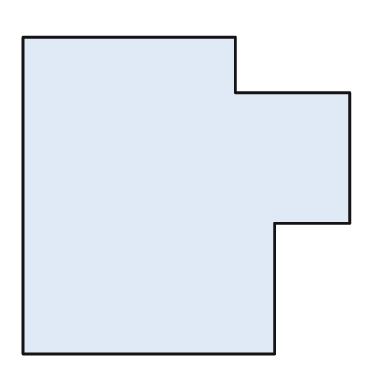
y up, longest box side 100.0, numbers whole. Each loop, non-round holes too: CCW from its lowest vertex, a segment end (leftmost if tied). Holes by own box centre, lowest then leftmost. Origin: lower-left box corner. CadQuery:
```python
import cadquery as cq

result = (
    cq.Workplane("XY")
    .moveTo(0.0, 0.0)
    .lineTo(77.0, 0.0)
    .lineTo(77.0, 40.0)
    .lineTo(100.0, 40.0)
    .lineTo(100.0, 80.0)
    .lineTo(65.0, 80.0)
    .lineTo(65.0, 97.0)
    .lineTo(0.0, 97.0)
    .close()
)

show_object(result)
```